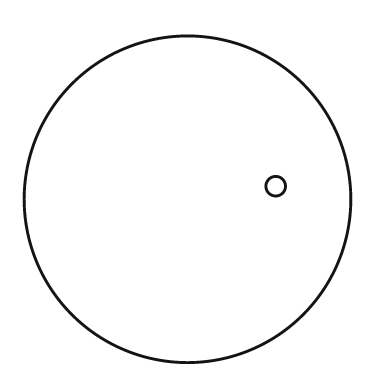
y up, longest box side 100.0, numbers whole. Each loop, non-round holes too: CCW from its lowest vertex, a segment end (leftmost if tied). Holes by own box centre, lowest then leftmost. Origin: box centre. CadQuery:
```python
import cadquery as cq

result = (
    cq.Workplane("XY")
    .moveTo(0.0, 0.0)
    .circle(50.0)
    .moveTo(27.0, 4.0)
    .circle(3.0)
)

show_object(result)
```